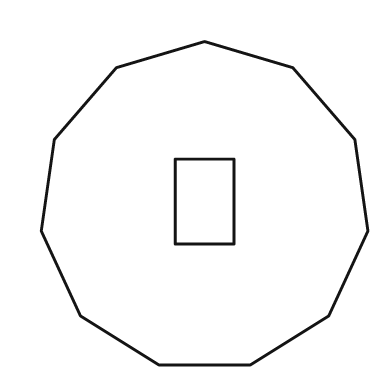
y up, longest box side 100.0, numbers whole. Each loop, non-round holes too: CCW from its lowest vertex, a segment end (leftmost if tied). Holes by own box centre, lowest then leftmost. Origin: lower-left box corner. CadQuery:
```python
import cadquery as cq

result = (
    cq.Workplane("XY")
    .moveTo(36.0, 0.0)
    .lineTo(64.0, 0.0)
    .lineTo(88.0, 15.0)
    .lineTo(100.0, 41.0)
    .lineTo(96.0, 69.0)
    .lineTo(77.0, 91.0)
    .lineTo(50.0, 99.0)
    .lineTo(23.0, 91.0)
    .lineTo(4.0, 69.0)
    .lineTo(0.0, 41.0)
    .lineTo(12.0, 15.0)
    .close()
    .moveTo(41.0, 37.0)
    .lineTo(59.0, 37.0)
    .lineTo(59.0, 63.0)
    .lineTo(41.0, 63.0)
    .close()
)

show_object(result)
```